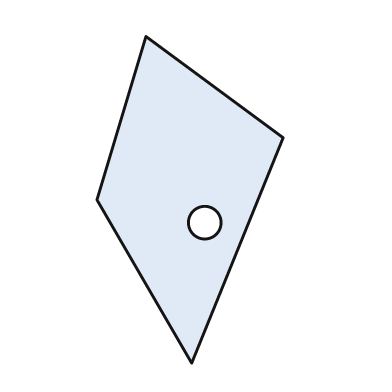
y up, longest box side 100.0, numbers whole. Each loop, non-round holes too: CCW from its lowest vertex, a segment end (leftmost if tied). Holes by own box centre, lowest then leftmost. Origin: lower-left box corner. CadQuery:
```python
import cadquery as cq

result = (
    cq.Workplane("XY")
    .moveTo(29.0, 0.0)
    .lineTo(57.0, 69.0)
    .lineTo(15.0, 100.0)
    .lineTo(0.0, 50.0)
    .close()
    .moveTo(33.0, 43.0)
    .circle(5.0)
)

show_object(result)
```